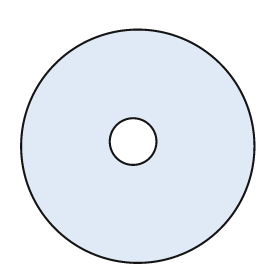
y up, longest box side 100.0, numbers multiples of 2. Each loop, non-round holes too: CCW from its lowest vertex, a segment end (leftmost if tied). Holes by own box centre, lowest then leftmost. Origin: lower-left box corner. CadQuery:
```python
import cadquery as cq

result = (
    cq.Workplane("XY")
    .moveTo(50.0, 50.0)
    .circle(50.0)
    .moveTo(48.0, 52.0)
    .circle(10.0)
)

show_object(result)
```